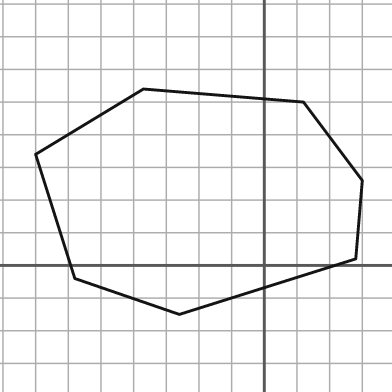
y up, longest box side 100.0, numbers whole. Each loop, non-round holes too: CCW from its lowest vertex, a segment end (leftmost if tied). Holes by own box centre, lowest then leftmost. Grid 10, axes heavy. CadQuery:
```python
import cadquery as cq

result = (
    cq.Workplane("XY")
    .moveTo(-26.0, -15.0)
    .lineTo(28.0, 2.0)
    .lineTo(30.0, 26.0)
    .lineTo(12.0, 50.0)
    .lineTo(-37.0, 54.0)
    .lineTo(-70.0, 34.0)
    .lineTo(-58.0, -4.0)
    .close()
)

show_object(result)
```